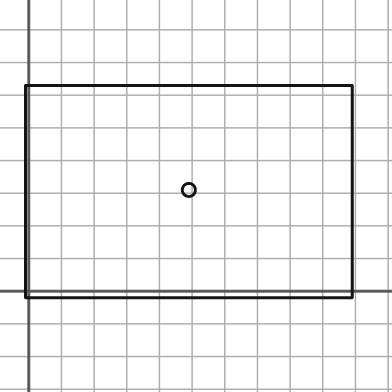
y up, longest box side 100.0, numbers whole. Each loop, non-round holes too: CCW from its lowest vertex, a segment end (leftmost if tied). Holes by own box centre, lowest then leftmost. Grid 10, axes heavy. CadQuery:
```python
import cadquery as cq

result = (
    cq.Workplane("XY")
    .moveTo(-1.0, -2.0)
    .lineTo(99.0, -2.0)
    .lineTo(99.0, 63.0)
    .lineTo(-1.0, 63.0)
    .close()
    .moveTo(49.0, 31.0)
    .circle(2.0)
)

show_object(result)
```